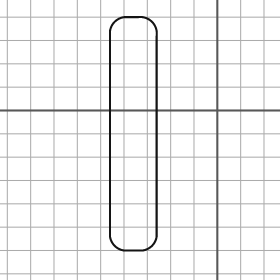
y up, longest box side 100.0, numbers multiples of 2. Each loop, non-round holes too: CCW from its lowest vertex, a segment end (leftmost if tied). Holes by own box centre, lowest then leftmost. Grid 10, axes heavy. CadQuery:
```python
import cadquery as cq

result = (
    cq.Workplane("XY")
    .moveTo(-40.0, -60.0)
    .lineTo(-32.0, -60.0)
    .threePointArc((-28.0, -58.0), (-26.0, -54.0))
    .lineTo(-26.0, 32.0)
    .threePointArc((-28.0, 38.0), (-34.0, 40.0))
    .lineTo(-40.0, 40.0)
    .threePointArc((-44.0, 38.0), (-46.0, 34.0))
    .lineTo(-46.0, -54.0)
    .threePointArc((-44.0, -58.0), (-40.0, -60.0))
    .close()
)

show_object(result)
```